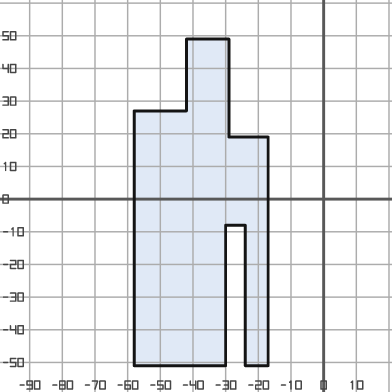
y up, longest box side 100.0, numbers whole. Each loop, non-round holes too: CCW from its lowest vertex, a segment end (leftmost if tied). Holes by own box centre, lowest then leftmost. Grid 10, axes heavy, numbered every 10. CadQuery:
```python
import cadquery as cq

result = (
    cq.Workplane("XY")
    .moveTo(-58.0, -51.0)
    .lineTo(-30.0, -51.0)
    .lineTo(-30.0, -8.0)
    .lineTo(-24.0, -8.0)
    .lineTo(-24.0, -51.0)
    .lineTo(-17.0, -51.0)
    .lineTo(-17.0, 19.0)
    .lineTo(-29.0, 19.0)
    .lineTo(-29.0, 49.0)
    .lineTo(-42.0, 49.0)
    .lineTo(-42.0, 27.0)
    .lineTo(-58.0, 27.0)
    .close()
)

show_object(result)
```